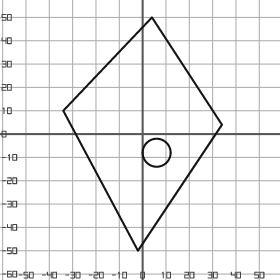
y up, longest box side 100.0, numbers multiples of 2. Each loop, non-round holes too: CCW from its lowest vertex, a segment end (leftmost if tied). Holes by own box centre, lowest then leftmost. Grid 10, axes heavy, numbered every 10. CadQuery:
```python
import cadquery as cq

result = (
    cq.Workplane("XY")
    .moveTo(-2.0, -50.0)
    .lineTo(34.0, 4.0)
    .lineTo(4.0, 50.0)
    .lineTo(-34.0, 10.0)
    .close()
    .moveTo(6.0, -8.0)
    .circle(6.0)
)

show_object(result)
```